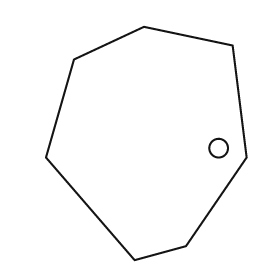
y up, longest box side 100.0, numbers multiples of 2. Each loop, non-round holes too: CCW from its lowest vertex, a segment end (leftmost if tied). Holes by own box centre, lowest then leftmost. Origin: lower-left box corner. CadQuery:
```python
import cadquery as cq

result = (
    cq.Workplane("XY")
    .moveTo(38.0, 0.0)
    .lineTo(60.0, 6.0)
    .lineTo(86.0, 44.0)
    .lineTo(80.0, 92.0)
    .lineTo(42.0, 100.0)
    .lineTo(12.0, 86.0)
    .lineTo(0.0, 44.0)
    .close()
    .moveTo(74.0, 48.0)
    .circle(4.0)
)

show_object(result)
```